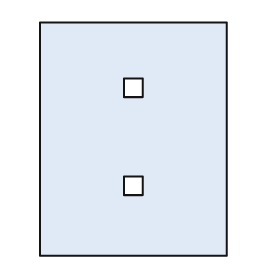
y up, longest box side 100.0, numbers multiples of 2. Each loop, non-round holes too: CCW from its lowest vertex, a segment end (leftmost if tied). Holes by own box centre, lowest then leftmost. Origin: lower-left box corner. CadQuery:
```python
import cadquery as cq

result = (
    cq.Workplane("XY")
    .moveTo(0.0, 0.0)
    .lineTo(80.0, 0.0)
    .lineTo(80.0, 100.0)
    .lineTo(0.0, 100.0)
    .close()
    .moveTo(36.0, 26.0)
    .lineTo(44.0, 26.0)
    .lineTo(44.0, 34.0)
    .lineTo(36.0, 34.0)
    .close()
    .moveTo(36.0, 68.0)
    .lineTo(44.0, 68.0)
    .lineTo(44.0, 76.0)
    .lineTo(36.0, 76.0)
    .close()
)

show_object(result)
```